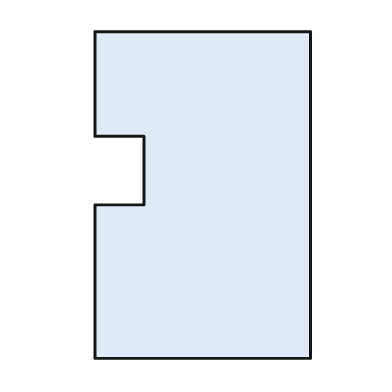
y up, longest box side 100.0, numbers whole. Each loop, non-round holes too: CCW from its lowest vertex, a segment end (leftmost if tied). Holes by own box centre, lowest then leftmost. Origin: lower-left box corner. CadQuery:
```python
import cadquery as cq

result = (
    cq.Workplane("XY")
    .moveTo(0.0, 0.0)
    .lineTo(66.0, 0.0)
    .lineTo(66.0, 100.0)
    .lineTo(0.0, 100.0)
    .lineTo(0.0, 68.0)
    .lineTo(15.0, 68.0)
    .lineTo(15.0, 47.0)
    .lineTo(0.0, 47.0)
    .close()
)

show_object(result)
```